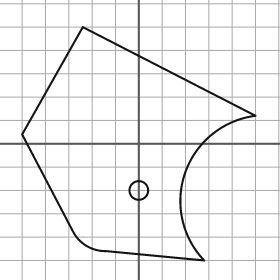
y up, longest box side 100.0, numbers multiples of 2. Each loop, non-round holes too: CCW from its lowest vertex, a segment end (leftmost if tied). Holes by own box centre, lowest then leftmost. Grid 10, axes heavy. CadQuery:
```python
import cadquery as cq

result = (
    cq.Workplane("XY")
    .moveTo(28.0, -50.0)
    .threePointArc((20.0, -12.0), (50.0, 12.0))
    .lineTo(-24.0, 50.0)
    .lineTo(-50.0, 4.0)
    .lineTo(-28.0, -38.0)
    .threePointArc((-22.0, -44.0), (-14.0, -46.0))
    .close()
    .moveTo(0.0, -20.0)
    .circle(4.0)
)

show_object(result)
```